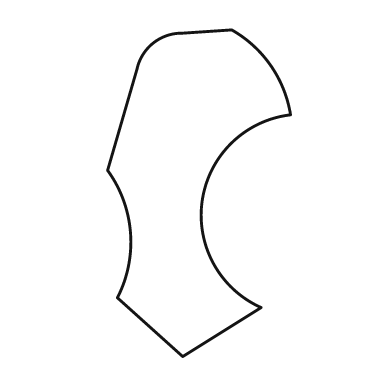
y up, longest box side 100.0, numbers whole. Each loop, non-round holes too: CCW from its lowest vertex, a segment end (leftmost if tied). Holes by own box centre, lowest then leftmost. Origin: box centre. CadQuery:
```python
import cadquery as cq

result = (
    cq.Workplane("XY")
    .moveTo(-5.0, -50.0)
    .lineTo(19.0, -35.0)
    .threePointArc((1.0, -2.0), (28.0, 24.0))
    .threePointArc((22.0, 39.0), (10.0, 50.0))
    .lineTo(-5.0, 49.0)
    .threePointArc((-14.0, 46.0), (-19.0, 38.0))
    .lineTo(-28.0, 7.0)
    .threePointArc((-21.0, -12.0), (-25.0, -32.0))
    .close()
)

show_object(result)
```